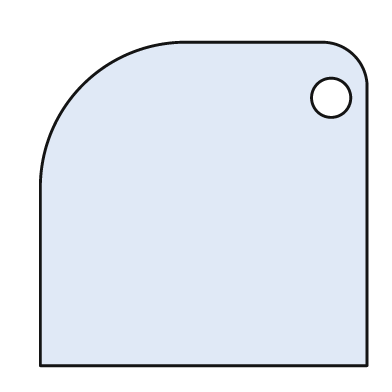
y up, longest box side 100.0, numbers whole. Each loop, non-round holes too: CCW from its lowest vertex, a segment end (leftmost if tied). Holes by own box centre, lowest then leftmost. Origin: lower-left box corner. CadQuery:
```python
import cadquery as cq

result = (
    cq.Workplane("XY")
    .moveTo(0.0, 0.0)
    .lineTo(100.0, 0.0)
    .lineTo(100.0, 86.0)
    .threePointArc((96.0, 95.0), (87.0, 99.0))
    .lineTo(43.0, 99.0)
    .threePointArc((13.0, 86.0), (0.0, 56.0))
    .close()
    .moveTo(89.0, 82.0)
    .circle(6.0)
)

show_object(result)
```